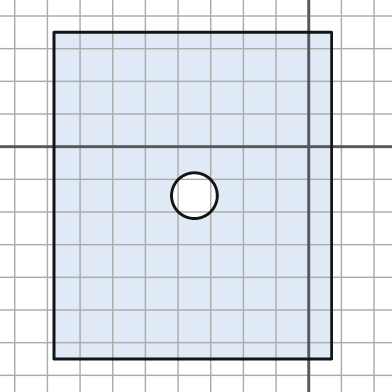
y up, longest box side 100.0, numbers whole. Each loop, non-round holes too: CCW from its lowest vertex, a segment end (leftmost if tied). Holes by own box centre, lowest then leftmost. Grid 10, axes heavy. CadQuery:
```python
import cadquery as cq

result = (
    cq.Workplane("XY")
    .moveTo(-78.0, -65.0)
    .lineTo(7.0, -65.0)
    .lineTo(7.0, 35.0)
    .lineTo(-78.0, 35.0)
    .close()
    .moveTo(-35.0, -15.0)
    .circle(7.0)
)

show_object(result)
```